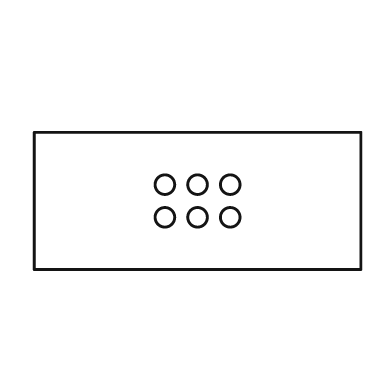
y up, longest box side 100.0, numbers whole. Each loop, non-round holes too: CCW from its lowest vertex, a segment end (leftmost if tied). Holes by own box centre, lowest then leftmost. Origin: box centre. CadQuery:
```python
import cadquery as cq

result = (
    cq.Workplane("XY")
    .moveTo(-50.0, -21.0)
    .lineTo(50.0, -21.0)
    .lineTo(50.0, 21.0)
    .lineTo(-50.0, 21.0)
    .close()
    .moveTo(-10.0, -5.0)
    .circle(3.0)
    .moveTo(0.0, -5.0)
    .circle(3.0)
    .moveTo(10.0, -5.0)
    .circle(3.0)
    .moveTo(-10.0, 5.0)
    .circle(3.0)
    .moveTo(0.0, 5.0)
    .circle(3.0)
    .moveTo(10.0, 5.0)
    .circle(3.0)
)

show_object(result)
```